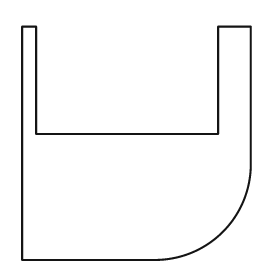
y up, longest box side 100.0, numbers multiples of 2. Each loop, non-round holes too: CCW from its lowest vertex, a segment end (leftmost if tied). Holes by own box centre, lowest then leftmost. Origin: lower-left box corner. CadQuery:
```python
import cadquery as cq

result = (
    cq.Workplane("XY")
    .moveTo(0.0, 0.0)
    .lineTo(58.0, 0.0)
    .threePointArc((86.0, 12.0), (98.0, 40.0))
    .lineTo(98.0, 100.0)
    .lineTo(84.0, 100.0)
    .lineTo(84.0, 54.0)
    .lineTo(6.0, 54.0)
    .lineTo(6.0, 100.0)
    .lineTo(0.0, 100.0)
    .close()
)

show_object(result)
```